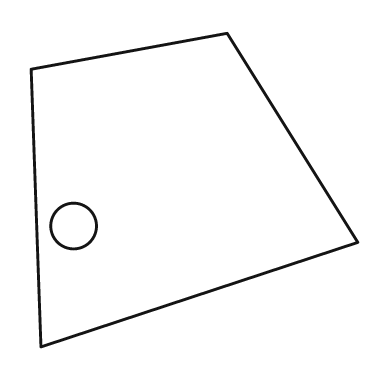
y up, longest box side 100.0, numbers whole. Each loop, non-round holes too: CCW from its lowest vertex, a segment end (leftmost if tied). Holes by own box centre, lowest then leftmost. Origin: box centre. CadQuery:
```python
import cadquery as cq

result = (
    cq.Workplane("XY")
    .moveTo(-47.0, -48.0)
    .lineTo(50.0, -16.0)
    .lineTo(10.0, 48.0)
    .lineTo(-50.0, 37.0)
    .close()
    .moveTo(-37.0, -11.0)
    .circle(7.0)
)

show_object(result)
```